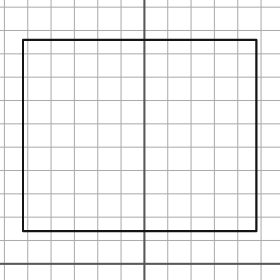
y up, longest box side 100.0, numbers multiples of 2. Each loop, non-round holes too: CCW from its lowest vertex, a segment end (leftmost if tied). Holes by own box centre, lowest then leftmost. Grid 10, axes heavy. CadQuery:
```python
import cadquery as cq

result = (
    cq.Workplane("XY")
    .moveTo(-52.0, 14.0)
    .lineTo(48.0, 14.0)
    .lineTo(48.0, 96.0)
    .lineTo(-52.0, 96.0)
    .close()
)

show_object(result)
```